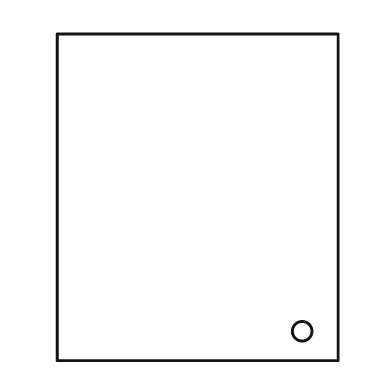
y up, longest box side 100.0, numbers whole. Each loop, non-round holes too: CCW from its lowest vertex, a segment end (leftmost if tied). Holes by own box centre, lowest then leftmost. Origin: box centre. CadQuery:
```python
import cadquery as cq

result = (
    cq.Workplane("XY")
    .moveTo(-43.0, -50.0)
    .lineTo(43.0, -50.0)
    .lineTo(43.0, 50.0)
    .lineTo(-43.0, 50.0)
    .close()
    .moveTo(32.0, -41.0)
    .circle(3.0)
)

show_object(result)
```